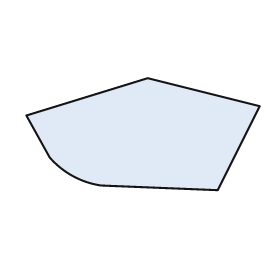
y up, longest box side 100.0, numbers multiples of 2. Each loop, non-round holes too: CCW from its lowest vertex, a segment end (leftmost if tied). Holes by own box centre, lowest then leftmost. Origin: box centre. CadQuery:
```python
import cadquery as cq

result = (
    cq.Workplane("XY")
    .moveTo(32.0, -24.0)
    .lineTo(50.0, 12.0)
    .lineTo(2.0, 24.0)
    .lineTo(-50.0, 8.0)
    .lineTo(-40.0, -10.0)
    .threePointArc((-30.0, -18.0), (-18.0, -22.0))
    .close()
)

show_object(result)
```